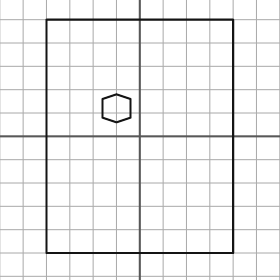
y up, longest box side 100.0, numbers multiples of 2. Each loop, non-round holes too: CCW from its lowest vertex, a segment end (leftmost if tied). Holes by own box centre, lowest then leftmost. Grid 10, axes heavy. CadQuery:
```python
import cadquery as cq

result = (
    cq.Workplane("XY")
    .moveTo(-40.0, -50.0)
    .lineTo(40.0, -50.0)
    .lineTo(40.0, 50.0)
    .lineTo(-40.0, 50.0)
    .close()
    .moveTo(-10.0, 6.0)
    .lineTo(-4.0, 8.0)
    .lineTo(-4.0, 16.0)
    .lineTo(-10.0, 18.0)
    .lineTo(-16.0, 16.0)
    .lineTo(-16.0, 8.0)
    .close()
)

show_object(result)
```